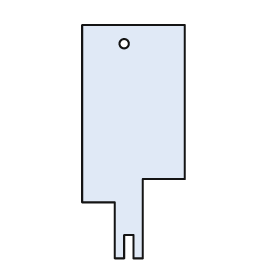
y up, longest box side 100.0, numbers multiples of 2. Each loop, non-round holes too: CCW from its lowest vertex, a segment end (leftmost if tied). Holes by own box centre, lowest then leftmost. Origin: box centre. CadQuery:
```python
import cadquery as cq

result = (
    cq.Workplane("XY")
    .moveTo(-8.0, -50.0)
    .lineTo(-4.0, -50.0)
    .lineTo(-4.0, -40.0)
    .lineTo(0.0, -40.0)
    .lineTo(0.0, -50.0)
    .lineTo(4.0, -50.0)
    .lineTo(4.0, -16.0)
    .lineTo(22.0, -16.0)
    .lineTo(22.0, 50.0)
    .lineTo(-22.0, 50.0)
    .lineTo(-22.0, -26.0)
    .lineTo(-8.0, -26.0)
    .close()
    .moveTo(-4.0, 42.0)
    .circle(2.0)
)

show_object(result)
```